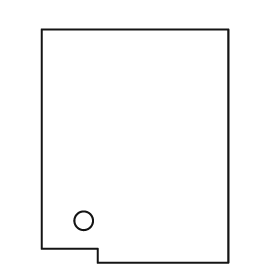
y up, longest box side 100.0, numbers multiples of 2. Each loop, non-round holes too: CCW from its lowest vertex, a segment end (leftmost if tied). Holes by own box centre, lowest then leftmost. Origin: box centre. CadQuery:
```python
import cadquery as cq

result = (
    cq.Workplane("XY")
    .moveTo(-16.0, -50.0)
    .lineTo(40.0, -50.0)
    .lineTo(40.0, 50.0)
    .lineTo(-40.0, 50.0)
    .lineTo(-40.0, -44.0)
    .lineTo(-16.0, -44.0)
    .close()
    .moveTo(-22.0, -32.0)
    .circle(4.0)
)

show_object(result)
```